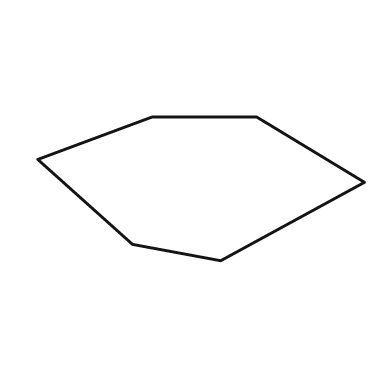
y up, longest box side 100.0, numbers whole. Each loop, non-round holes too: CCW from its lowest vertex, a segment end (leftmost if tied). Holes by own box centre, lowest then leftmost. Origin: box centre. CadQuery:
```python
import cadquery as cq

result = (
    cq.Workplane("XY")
    .moveTo(6.0, -22.0)
    .lineTo(50.0, 2.0)
    .lineTo(17.0, 22.0)
    .lineTo(-15.0, 22.0)
    .lineTo(-50.0, 9.0)
    .lineTo(-21.0, -17.0)
    .close()
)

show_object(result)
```